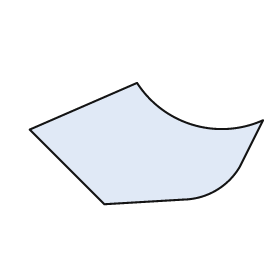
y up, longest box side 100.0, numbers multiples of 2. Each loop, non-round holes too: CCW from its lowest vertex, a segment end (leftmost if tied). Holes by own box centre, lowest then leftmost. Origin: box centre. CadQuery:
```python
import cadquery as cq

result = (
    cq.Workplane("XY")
    .moveTo(-18.0, -26.0)
    .lineTo(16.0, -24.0)
    .threePointArc((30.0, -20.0), (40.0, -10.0))
    .lineTo(50.0, 10.0)
    .threePointArc((20.0, 8.0), (-4.0, 26.0))
    .lineTo(-50.0, 6.0)
    .close()
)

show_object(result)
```